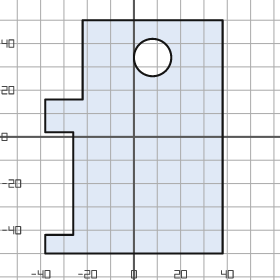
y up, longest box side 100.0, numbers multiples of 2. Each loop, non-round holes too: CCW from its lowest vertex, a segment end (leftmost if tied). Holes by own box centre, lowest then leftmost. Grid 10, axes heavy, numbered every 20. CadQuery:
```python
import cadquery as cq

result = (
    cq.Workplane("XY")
    .moveTo(-38.0, -50.0)
    .lineTo(38.0, -50.0)
    .lineTo(38.0, 50.0)
    .lineTo(-22.0, 50.0)
    .lineTo(-22.0, 16.0)
    .lineTo(-38.0, 16.0)
    .lineTo(-38.0, 2.0)
    .lineTo(-26.0, 2.0)
    .lineTo(-26.0, -42.0)
    .lineTo(-38.0, -42.0)
    .close()
    .moveTo(8.0, 34.0)
    .circle(8.0)
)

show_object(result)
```